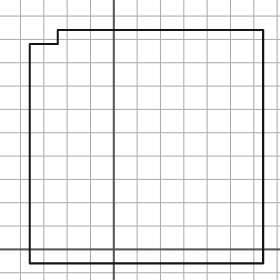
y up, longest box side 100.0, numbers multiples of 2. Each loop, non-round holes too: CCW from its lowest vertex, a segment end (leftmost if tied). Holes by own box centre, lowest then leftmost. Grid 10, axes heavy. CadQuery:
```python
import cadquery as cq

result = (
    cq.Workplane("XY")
    .moveTo(-36.0, -6.0)
    .lineTo(64.0, -6.0)
    .lineTo(64.0, 94.0)
    .lineTo(-24.0, 94.0)
    .lineTo(-24.0, 88.0)
    .lineTo(-36.0, 88.0)
    .close()
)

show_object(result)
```